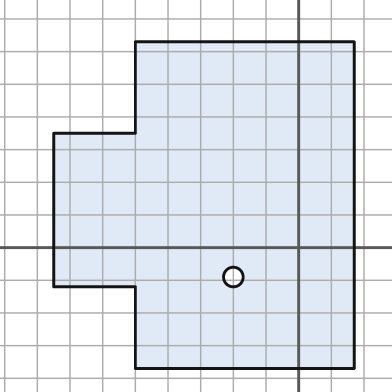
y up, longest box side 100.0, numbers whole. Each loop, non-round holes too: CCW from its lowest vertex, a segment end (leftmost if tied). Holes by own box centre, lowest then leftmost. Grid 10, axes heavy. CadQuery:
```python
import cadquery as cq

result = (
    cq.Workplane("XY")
    .moveTo(-50.0, -37.0)
    .lineTo(17.0, -37.0)
    .lineTo(17.0, 63.0)
    .lineTo(-50.0, 63.0)
    .lineTo(-50.0, 35.0)
    .lineTo(-75.0, 35.0)
    .lineTo(-75.0, -12.0)
    .lineTo(-50.0, -12.0)
    .close()
    .moveTo(-20.0, -9.0)
    .circle(3.0)
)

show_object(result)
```